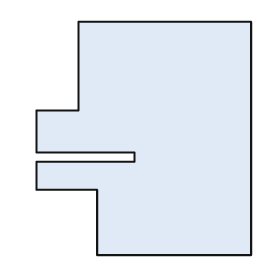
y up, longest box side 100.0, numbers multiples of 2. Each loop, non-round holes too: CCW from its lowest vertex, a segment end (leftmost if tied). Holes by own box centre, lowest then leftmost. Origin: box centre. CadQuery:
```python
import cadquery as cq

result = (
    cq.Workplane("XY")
    .moveTo(-20.0, -50.0)
    .lineTo(46.0, -50.0)
    .lineTo(46.0, 50.0)
    .lineTo(-28.0, 50.0)
    .lineTo(-28.0, 12.0)
    .lineTo(-46.0, 12.0)
    .lineTo(-46.0, -6.0)
    .lineTo(-4.0, -6.0)
    .lineTo(-4.0, -10.0)
    .lineTo(-46.0, -10.0)
    .lineTo(-46.0, -22.0)
    .lineTo(-20.0, -22.0)
    .close()
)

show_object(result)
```